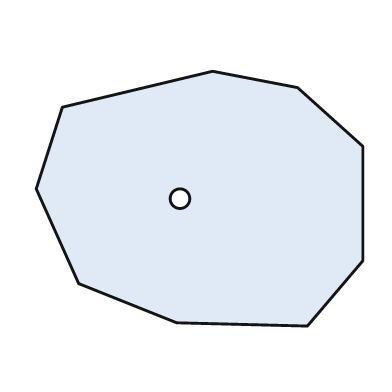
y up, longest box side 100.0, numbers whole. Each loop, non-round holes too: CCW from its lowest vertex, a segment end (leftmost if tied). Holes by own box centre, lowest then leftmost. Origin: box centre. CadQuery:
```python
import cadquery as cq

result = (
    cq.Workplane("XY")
    .moveTo(33.0, -39.0)
    .lineTo(50.0, -19.0)
    .lineTo(50.0, 16.0)
    .lineTo(30.0, 34.0)
    .lineTo(4.0, 39.0)
    .lineTo(-42.0, 28.0)
    .lineTo(-50.0, 3.0)
    .lineTo(-37.0, -26.0)
    .lineTo(-7.0, -38.0)
    .close()
    .moveTo(-6.0, 0.0)
    .circle(3.0)
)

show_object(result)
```